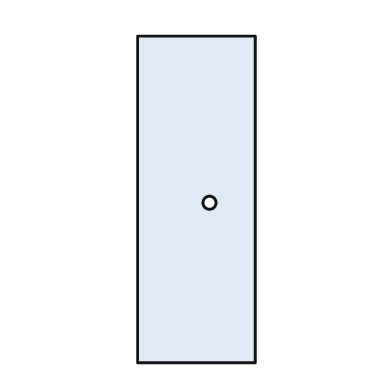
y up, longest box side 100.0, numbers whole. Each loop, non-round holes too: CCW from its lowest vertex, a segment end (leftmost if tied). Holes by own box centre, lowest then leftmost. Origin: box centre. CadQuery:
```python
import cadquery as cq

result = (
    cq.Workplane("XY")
    .moveTo(-18.0, -50.0)
    .lineTo(18.0, -50.0)
    .lineTo(18.0, 50.0)
    .lineTo(-18.0, 50.0)
    .close()
    .moveTo(4.0, -1.0)
    .circle(2.0)
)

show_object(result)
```